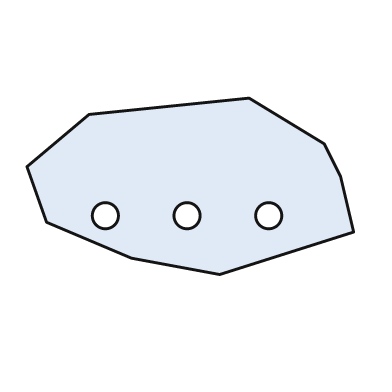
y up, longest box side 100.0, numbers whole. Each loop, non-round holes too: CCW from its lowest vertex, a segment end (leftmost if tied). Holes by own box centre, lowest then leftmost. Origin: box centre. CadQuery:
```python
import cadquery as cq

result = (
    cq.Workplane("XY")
    .moveTo(9.0, -27.0)
    .lineTo(50.0, -14.0)
    .lineTo(46.0, 3.0)
    .lineTo(41.0, 13.0)
    .lineTo(18.0, 27.0)
    .lineTo(-31.0, 22.0)
    .lineTo(-50.0, 6.0)
    .lineTo(-44.0, -11.0)
    .lineTo(-18.0, -22.0)
    .close()
    .moveTo(-26.0, -9.0)
    .circle(4.0)
    .moveTo(-1.0, -9.0)
    .circle(4.0)
    .moveTo(24.0, -9.0)
    .circle(4.0)
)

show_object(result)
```